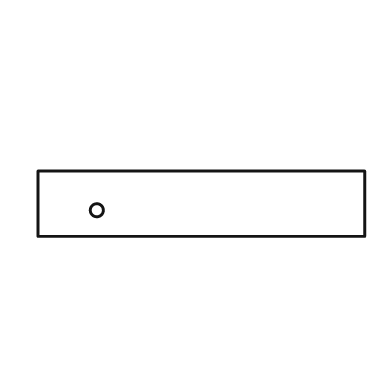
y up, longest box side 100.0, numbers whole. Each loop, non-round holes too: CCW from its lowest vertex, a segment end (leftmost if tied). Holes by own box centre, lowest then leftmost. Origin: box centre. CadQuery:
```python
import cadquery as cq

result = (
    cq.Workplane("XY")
    .moveTo(-50.0, -10.0)
    .lineTo(50.0, -10.0)
    .lineTo(50.0, 10.0)
    .lineTo(-50.0, 10.0)
    .close()
    .moveTo(-32.0, -2.0)
    .circle(2.0)
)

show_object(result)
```